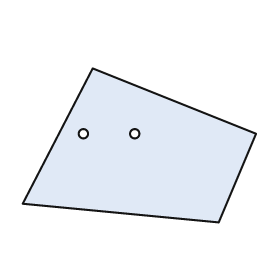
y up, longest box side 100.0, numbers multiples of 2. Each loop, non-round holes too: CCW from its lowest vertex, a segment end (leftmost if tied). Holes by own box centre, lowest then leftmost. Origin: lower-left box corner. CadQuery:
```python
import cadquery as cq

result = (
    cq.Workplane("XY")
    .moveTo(84.0, 0.0)
    .lineTo(100.0, 38.0)
    .lineTo(30.0, 66.0)
    .lineTo(0.0, 8.0)
    .close()
    .moveTo(26.0, 38.0)
    .circle(2.0)
    .moveTo(48.0, 38.0)
    .circle(2.0)
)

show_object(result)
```